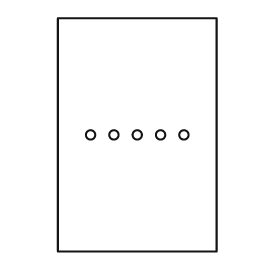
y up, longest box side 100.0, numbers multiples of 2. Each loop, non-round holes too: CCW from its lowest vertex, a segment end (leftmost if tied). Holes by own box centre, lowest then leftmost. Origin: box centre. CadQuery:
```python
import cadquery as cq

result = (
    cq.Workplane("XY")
    .moveTo(-34.0, -50.0)
    .lineTo(34.0, -50.0)
    .lineTo(34.0, 50.0)
    .lineTo(-34.0, 50.0)
    .close()
    .moveTo(-20.0, 0.0)
    .circle(2.0)
    .moveTo(-10.0, 0.0)
    .circle(2.0)
    .moveTo(0.0, 0.0)
    .circle(2.0)
    .moveTo(10.0, 0.0)
    .circle(2.0)
    .moveTo(20.0, 0.0)
    .circle(2.0)
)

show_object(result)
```